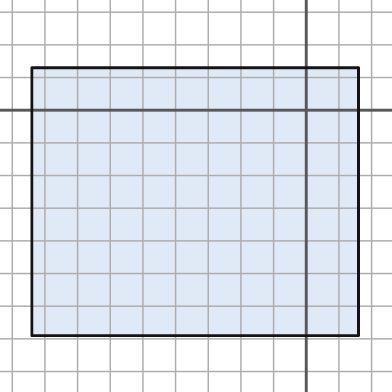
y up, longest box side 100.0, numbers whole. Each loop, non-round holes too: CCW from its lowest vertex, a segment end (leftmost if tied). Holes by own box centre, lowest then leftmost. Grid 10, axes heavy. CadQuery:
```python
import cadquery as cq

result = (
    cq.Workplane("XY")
    .moveTo(-84.0, -69.0)
    .lineTo(16.0, -69.0)
    .lineTo(16.0, 13.0)
    .lineTo(-84.0, 13.0)
    .close()
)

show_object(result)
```